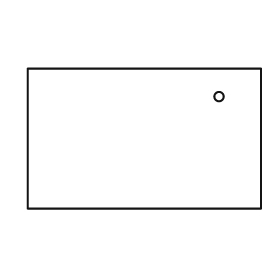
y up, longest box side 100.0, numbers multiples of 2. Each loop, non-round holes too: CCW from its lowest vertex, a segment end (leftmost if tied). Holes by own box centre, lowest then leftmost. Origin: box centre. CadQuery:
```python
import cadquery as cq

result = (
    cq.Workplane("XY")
    .moveTo(-50.0, -30.0)
    .lineTo(50.0, -30.0)
    .lineTo(50.0, 30.0)
    .lineTo(-50.0, 30.0)
    .close()
    .moveTo(32.0, 18.0)
    .circle(2.0)
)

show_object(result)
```